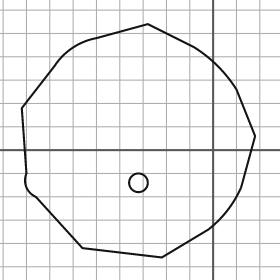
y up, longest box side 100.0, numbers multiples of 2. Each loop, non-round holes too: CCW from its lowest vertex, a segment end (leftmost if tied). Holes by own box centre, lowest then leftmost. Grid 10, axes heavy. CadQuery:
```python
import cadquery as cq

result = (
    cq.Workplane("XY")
    .moveTo(-22.0, -46.0)
    .lineTo(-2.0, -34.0)
    .threePointArc((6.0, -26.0), (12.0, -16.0))
    .lineTo(18.0, 6.0)
    .lineTo(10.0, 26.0)
    .threePointArc((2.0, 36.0), (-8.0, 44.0))
    .lineTo(-28.0, 54.0)
    .lineTo(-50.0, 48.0)
    .threePointArc((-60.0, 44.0), (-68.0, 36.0))
    .lineTo(-82.0, 18.0)
    .lineTo(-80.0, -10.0)
    .threePointArc((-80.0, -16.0), (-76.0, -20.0))
    .lineTo(-56.0, -42.0)
    .close()
    .moveTo(-32.0, -14.0)
    .circle(4.0)
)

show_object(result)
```